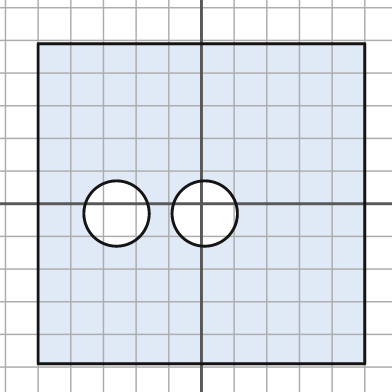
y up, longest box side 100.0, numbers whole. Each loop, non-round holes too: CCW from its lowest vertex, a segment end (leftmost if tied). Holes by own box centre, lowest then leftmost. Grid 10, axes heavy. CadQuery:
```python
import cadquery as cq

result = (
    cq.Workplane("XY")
    .moveTo(-50.0, -49.0)
    .lineTo(50.0, -49.0)
    .lineTo(50.0, 49.0)
    .lineTo(-50.0, 49.0)
    .close()
    .moveTo(-26.0, -3.0)
    .circle(10.0)
    .moveTo(1.0, -3.0)
    .circle(10.0)
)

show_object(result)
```